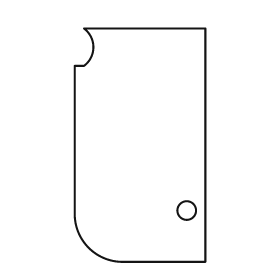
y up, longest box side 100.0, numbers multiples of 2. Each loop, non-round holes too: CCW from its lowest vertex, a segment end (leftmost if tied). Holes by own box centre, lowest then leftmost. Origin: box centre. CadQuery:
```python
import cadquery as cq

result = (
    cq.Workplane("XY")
    .moveTo(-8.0, -50.0)
    .lineTo(28.0, -50.0)
    .lineTo(28.0, 50.0)
    .lineTo(-24.0, 50.0)
    .threePointArc((-20.0, 42.0), (-24.0, 34.0))
    .lineTo(-28.0, 34.0)
    .lineTo(-28.0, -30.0)
    .threePointArc((-22.0, -44.0), (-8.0, -50.0))
    .close()
    .moveTo(20.0, -28.0)
    .circle(4.0)
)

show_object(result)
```